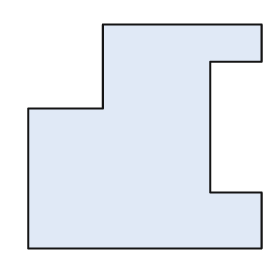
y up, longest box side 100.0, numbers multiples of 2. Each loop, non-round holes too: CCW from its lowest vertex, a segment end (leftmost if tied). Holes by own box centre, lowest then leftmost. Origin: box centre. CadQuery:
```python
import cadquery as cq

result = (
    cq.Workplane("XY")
    .moveTo(-50.0, -48.0)
    .lineTo(50.0, -48.0)
    .lineTo(50.0, -24.0)
    .lineTo(28.0, -24.0)
    .lineTo(28.0, 32.0)
    .lineTo(50.0, 32.0)
    .lineTo(50.0, 48.0)
    .lineTo(-18.0, 48.0)
    .lineTo(-18.0, 12.0)
    .lineTo(-50.0, 12.0)
    .close()
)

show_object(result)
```